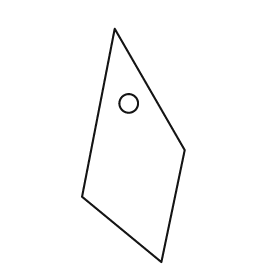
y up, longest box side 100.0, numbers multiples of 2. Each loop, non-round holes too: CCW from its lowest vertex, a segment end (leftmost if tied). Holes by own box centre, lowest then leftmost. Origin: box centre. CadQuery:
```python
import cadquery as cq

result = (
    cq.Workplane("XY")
    .moveTo(12.0, -50.0)
    .lineTo(22.0, -2.0)
    .lineTo(-8.0, 50.0)
    .lineTo(-22.0, -22.0)
    .close()
    .moveTo(-2.0, 18.0)
    .circle(4.0)
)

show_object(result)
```